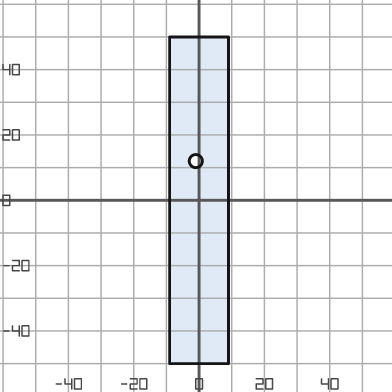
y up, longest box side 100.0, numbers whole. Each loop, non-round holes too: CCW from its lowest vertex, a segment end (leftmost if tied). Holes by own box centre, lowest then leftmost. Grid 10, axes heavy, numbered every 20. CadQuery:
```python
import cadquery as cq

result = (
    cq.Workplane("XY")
    .moveTo(-9.0, -50.0)
    .lineTo(9.0, -50.0)
    .lineTo(9.0, 50.0)
    .lineTo(-9.0, 50.0)
    .close()
    .moveTo(-1.0, 12.0)
    .circle(2.0)
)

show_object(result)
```